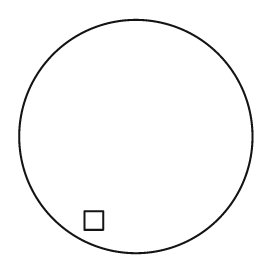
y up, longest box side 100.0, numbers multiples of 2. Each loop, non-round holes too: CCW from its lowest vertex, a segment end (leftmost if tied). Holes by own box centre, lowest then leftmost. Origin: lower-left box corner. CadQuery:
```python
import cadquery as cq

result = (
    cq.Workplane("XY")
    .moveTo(50.0, 50.0)
    .circle(50.0)
    .moveTo(28.0, 10.0)
    .lineTo(36.0, 10.0)
    .lineTo(36.0, 18.0)
    .lineTo(28.0, 18.0)
    .close()
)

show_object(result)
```